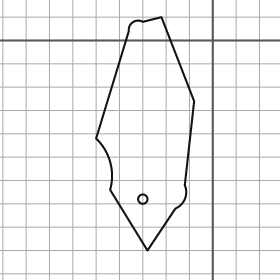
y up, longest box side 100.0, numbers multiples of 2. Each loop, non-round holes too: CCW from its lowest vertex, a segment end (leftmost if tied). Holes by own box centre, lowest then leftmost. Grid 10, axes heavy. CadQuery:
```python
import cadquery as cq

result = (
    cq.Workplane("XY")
    .moveTo(-28.0, -90.0)
    .lineTo(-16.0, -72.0)
    .threePointArc((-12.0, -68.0), (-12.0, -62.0))
    .lineTo(-8.0, -26.0)
    .lineTo(-22.0, 10.0)
    .lineTo(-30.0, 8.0)
    .threePointArc((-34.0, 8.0), (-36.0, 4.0))
    .lineTo(-50.0, -42.0)
    .threePointArc((-44.0, -52.0), (-44.0, -64.0))
    .close()
    .moveTo(-30.0, -68.0)
    .circle(2.0)
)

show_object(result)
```